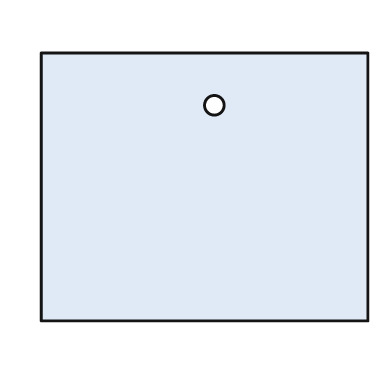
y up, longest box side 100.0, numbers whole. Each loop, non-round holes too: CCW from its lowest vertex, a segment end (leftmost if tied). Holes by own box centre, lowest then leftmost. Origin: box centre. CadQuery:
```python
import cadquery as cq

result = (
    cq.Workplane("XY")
    .moveTo(-50.0, -41.0)
    .lineTo(50.0, -41.0)
    .lineTo(50.0, 41.0)
    .lineTo(-50.0, 41.0)
    .close()
    .moveTo(3.0, 25.0)
    .circle(3.0)
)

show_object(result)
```